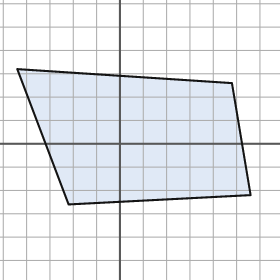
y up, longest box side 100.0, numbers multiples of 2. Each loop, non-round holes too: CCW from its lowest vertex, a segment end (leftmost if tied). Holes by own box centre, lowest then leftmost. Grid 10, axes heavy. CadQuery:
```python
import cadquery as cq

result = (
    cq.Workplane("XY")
    .moveTo(-22.0, -26.0)
    .lineTo(56.0, -22.0)
    .lineTo(48.0, 26.0)
    .lineTo(-44.0, 32.0)
    .close()
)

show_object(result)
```